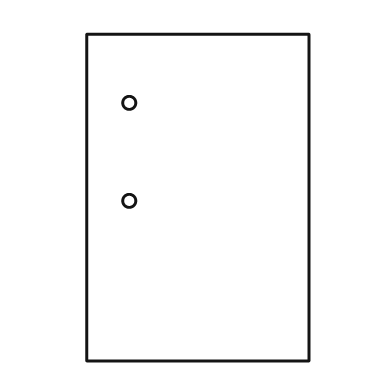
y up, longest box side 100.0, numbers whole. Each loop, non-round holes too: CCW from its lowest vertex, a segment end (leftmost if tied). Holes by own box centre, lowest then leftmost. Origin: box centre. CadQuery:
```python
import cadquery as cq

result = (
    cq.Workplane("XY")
    .moveTo(-34.0, -50.0)
    .lineTo(34.0, -50.0)
    .lineTo(34.0, 50.0)
    .lineTo(-34.0, 50.0)
    .close()
    .moveTo(-21.0, -1.0)
    .circle(2.0)
    .moveTo(-21.0, 29.0)
    .circle(2.0)
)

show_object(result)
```